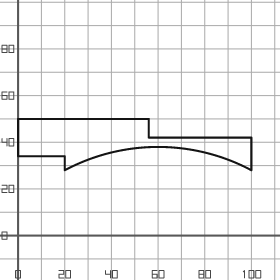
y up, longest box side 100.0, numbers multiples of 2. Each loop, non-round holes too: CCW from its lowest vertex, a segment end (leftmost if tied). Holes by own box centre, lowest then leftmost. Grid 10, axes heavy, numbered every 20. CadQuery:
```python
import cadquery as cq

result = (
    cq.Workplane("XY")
    .moveTo(20.0, 28.0)
    .threePointArc((60.0, 38.0), (100.0, 28.0))
    .lineTo(100.0, 42.0)
    .lineTo(56.0, 42.0)
    .lineTo(56.0, 50.0)
    .lineTo(0.0, 50.0)
    .lineTo(0.0, 34.0)
    .lineTo(20.0, 34.0)
    .close()
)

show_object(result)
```